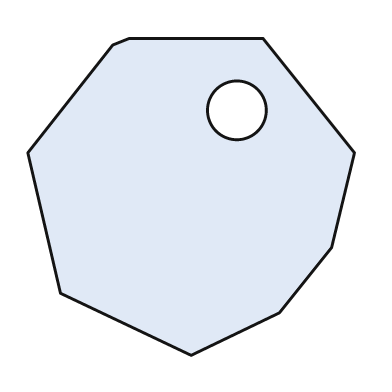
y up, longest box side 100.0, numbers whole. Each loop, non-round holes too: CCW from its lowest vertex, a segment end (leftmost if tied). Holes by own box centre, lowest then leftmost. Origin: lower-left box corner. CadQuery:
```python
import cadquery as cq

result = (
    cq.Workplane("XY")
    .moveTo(50.0, 0.0)
    .lineTo(77.0, 13.0)
    .lineTo(93.0, 33.0)
    .lineTo(100.0, 62.0)
    .lineTo(72.0, 97.0)
    .lineTo(31.0, 97.0)
    .lineTo(26.0, 95.0)
    .lineTo(0.0, 62.0)
    .lineTo(10.0, 19.0)
    .close()
    .moveTo(64.0, 75.0)
    .circle(9.0)
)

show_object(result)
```